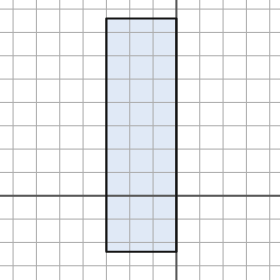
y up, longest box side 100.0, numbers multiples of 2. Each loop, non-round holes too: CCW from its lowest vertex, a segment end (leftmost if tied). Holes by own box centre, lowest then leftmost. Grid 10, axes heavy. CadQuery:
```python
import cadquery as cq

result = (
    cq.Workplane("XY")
    .moveTo(-30.0, -24.0)
    .lineTo(0.0, -24.0)
    .lineTo(0.0, 76.0)
    .lineTo(-30.0, 76.0)
    .close()
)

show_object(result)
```